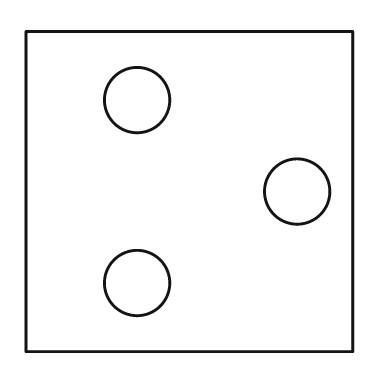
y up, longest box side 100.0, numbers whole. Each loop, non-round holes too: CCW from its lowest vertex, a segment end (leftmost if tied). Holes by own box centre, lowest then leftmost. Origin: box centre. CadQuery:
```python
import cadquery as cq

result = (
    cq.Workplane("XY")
    .moveTo(-50.0, -49.0)
    .lineTo(50.0, -49.0)
    .lineTo(50.0, 49.0)
    .lineTo(-50.0, 49.0)
    .close()
    .moveTo(-16.0, -28.0)
    .circle(10.0)
    .moveTo(33.0, 0.0)
    .circle(10.0)
    .moveTo(-16.0, 28.0)
    .circle(10.0)
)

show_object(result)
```